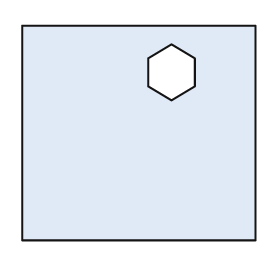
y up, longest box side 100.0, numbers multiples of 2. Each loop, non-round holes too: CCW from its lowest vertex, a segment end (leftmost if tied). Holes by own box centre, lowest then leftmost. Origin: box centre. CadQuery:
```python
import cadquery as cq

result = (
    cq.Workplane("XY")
    .moveTo(-50.0, -46.0)
    .lineTo(50.0, -46.0)
    .lineTo(50.0, 46.0)
    .lineTo(-50.0, 46.0)
    .close()
    .moveTo(14.0, 14.0)
    .lineTo(24.0, 20.0)
    .lineTo(24.0, 32.0)
    .lineTo(14.0, 38.0)
    .lineTo(4.0, 32.0)
    .lineTo(4.0, 20.0)
    .close()
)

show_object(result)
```